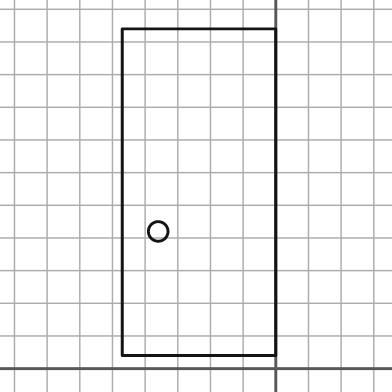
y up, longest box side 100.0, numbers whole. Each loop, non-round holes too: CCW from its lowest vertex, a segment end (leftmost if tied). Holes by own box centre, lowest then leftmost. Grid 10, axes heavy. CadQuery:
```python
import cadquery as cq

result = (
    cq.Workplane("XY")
    .moveTo(-47.0, 4.0)
    .lineTo(0.0, 4.0)
    .lineTo(0.0, 104.0)
    .lineTo(-47.0, 104.0)
    .close()
    .moveTo(-36.0, 42.0)
    .circle(3.0)
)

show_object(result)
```